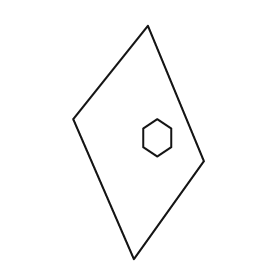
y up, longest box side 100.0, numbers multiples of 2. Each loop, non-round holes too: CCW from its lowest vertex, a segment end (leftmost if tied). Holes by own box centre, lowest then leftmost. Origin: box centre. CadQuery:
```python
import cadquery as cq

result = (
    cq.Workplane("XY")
    .moveTo(-2.0, -50.0)
    .lineTo(28.0, -8.0)
    .lineTo(4.0, 50.0)
    .lineTo(-28.0, 10.0)
    .close()
    .moveTo(8.0, -6.0)
    .lineTo(14.0, -2.0)
    .lineTo(14.0, 6.0)
    .lineTo(8.0, 10.0)
    .lineTo(2.0, 6.0)
    .lineTo(2.0, -2.0)
    .close()
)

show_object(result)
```